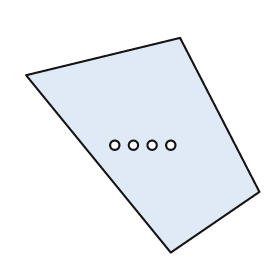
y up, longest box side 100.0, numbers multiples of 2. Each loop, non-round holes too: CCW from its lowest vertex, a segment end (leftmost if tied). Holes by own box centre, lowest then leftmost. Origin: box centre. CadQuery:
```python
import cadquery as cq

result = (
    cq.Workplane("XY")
    .moveTo(12.0, -46.0)
    .lineTo(50.0, -20.0)
    .lineTo(16.0, 46.0)
    .lineTo(-50.0, 30.0)
    .close()
    .moveTo(-12.0, 0.0)
    .circle(2.0)
    .moveTo(-4.0, 0.0)
    .circle(2.0)
    .moveTo(4.0, 0.0)
    .circle(2.0)
    .moveTo(12.0, 0.0)
    .circle(2.0)
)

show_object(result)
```